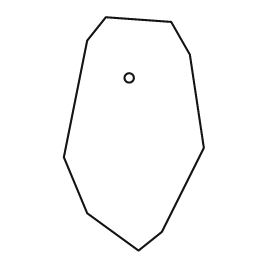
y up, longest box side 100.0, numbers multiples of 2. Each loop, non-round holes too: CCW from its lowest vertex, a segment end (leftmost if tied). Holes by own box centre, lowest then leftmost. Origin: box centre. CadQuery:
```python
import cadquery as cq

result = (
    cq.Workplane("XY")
    .moveTo(2.0, -50.0)
    .lineTo(12.0, -42.0)
    .lineTo(30.0, -6.0)
    .lineTo(24.0, 34.0)
    .lineTo(16.0, 48.0)
    .lineTo(-12.0, 50.0)
    .lineTo(-20.0, 40.0)
    .lineTo(-30.0, -10.0)
    .lineTo(-20.0, -34.0)
    .close()
    .moveTo(-2.0, 24.0)
    .circle(2.0)
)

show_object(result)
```